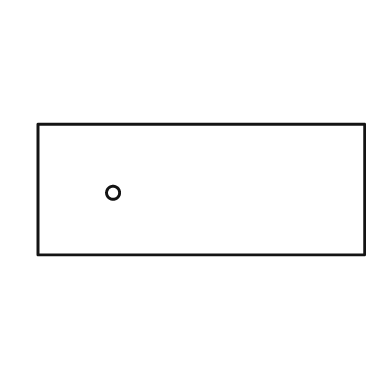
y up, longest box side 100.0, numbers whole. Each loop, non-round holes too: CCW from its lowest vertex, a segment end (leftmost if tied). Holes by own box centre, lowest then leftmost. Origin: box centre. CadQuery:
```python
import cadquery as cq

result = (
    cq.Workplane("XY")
    .moveTo(-50.0, -20.0)
    .lineTo(50.0, -20.0)
    .lineTo(50.0, 20.0)
    .lineTo(-50.0, 20.0)
    .close()
    .moveTo(-27.0, -1.0)
    .circle(2.0)
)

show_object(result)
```